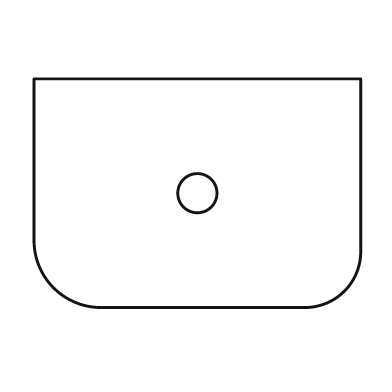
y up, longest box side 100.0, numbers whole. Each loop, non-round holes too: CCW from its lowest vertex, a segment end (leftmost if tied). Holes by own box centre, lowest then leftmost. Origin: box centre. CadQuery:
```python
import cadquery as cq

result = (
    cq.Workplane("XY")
    .moveTo(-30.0, -35.0)
    .lineTo(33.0, -35.0)
    .threePointArc((45.0, -30.0), (50.0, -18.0))
    .lineTo(50.0, 35.0)
    .lineTo(-50.0, 35.0)
    .lineTo(-50.0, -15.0)
    .threePointArc((-44.0, -29.0), (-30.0, -35.0))
    .close()
    .moveTo(0.0, 0.0)
    .circle(6.0)
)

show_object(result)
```